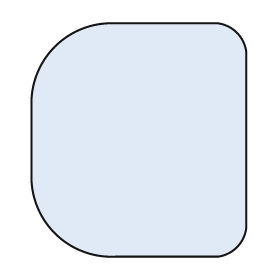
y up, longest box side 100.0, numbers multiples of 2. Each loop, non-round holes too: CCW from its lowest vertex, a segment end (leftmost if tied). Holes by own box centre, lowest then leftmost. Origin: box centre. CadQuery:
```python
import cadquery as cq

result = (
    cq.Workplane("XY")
    .moveTo(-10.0, -50.0)
    .lineTo(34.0, -50.0)
    .threePointArc((42.0, -46.0), (46.0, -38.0))
    .lineTo(46.0, 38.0)
    .threePointArc((42.0, 46.0), (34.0, 50.0))
    .lineTo(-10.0, 50.0)
    .threePointArc((-36.0, 40.0), (-46.0, 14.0))
    .lineTo(-46.0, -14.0)
    .threePointArc((-36.0, -40.0), (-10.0, -50.0))
    .close()
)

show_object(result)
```